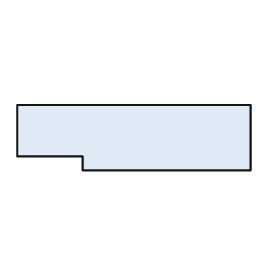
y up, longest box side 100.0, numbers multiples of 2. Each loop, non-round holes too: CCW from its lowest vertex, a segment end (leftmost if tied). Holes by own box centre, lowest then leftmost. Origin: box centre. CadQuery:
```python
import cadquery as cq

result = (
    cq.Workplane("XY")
    .moveTo(-22.0, -14.0)
    .lineTo(50.0, -14.0)
    .lineTo(50.0, 14.0)
    .lineTo(-50.0, 14.0)
    .lineTo(-50.0, -8.0)
    .lineTo(-22.0, -8.0)
    .close()
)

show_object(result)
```